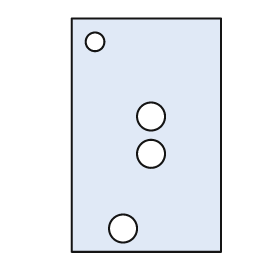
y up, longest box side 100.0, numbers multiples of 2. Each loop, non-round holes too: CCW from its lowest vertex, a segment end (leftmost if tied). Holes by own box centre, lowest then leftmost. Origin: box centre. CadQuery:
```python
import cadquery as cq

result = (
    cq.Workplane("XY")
    .moveTo(-32.0, -50.0)
    .lineTo(32.0, -50.0)
    .lineTo(32.0, 50.0)
    .lineTo(-32.0, 50.0)
    .close()
    .moveTo(-10.0, -40.0)
    .circle(6.0)
    .moveTo(2.0, -8.0)
    .circle(6.0)
    .moveTo(2.0, 8.0)
    .circle(6.0)
    .moveTo(-22.0, 40.0)
    .circle(4.0)
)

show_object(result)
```